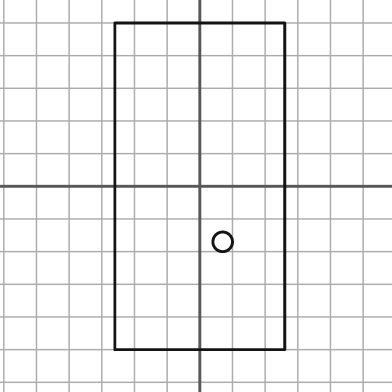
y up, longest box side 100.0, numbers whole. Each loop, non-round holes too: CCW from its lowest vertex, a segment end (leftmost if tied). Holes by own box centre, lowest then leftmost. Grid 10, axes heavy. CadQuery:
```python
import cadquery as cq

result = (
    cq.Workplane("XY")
    .moveTo(-26.0, -50.0)
    .lineTo(26.0, -50.0)
    .lineTo(26.0, 50.0)
    .lineTo(-26.0, 50.0)
    .close()
    .moveTo(7.0, -17.0)
    .circle(3.0)
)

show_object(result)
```